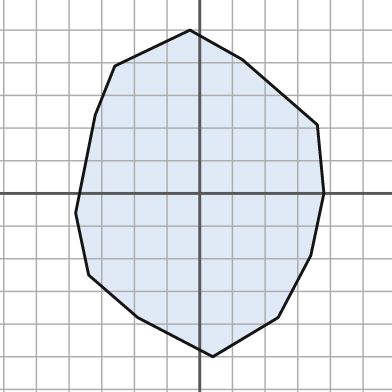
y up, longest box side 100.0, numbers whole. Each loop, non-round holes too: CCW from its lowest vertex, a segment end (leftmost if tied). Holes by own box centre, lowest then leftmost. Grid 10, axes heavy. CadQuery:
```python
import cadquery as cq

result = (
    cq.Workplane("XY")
    .moveTo(4.0, -50.0)
    .lineTo(24.0, -38.0)
    .lineTo(34.0, -19.0)
    .lineTo(38.0, 0.0)
    .lineTo(36.0, 21.0)
    .lineTo(13.0, 41.0)
    .lineTo(-3.0, 50.0)
    .lineTo(-26.0, 39.0)
    .lineTo(-32.0, 24.0)
    .lineTo(-38.0, -6.0)
    .lineTo(-34.0, -25.0)
    .lineTo(-19.0, -38.0)
    .close()
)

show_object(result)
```